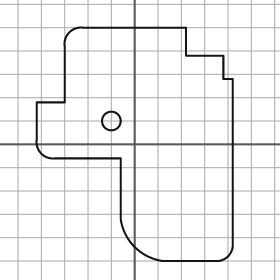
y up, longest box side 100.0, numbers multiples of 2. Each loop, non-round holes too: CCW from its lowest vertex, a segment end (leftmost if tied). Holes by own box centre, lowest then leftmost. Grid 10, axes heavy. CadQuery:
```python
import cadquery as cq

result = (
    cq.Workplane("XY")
    .moveTo(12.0, -50.0)
    .lineTo(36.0, -50.0)
    .threePointArc((40.0, -48.0), (42.0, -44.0))
    .lineTo(42.0, 28.0)
    .lineTo(38.0, 28.0)
    .lineTo(38.0, 38.0)
    .lineTo(22.0, 38.0)
    .lineTo(22.0, 50.0)
    .lineTo(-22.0, 50.0)
    .threePointArc((-28.0, 48.0), (-30.0, 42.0))
    .lineTo(-30.0, 18.0)
    .lineTo(-42.0, 18.0)
    .lineTo(-42.0, 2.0)
    .threePointArc((-40.0, -4.0), (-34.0, -6.0))
    .lineTo(-6.0, -6.0)
    .lineTo(-6.0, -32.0)
    .threePointArc((0.0, -44.0), (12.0, -50.0))
    .close()
    .moveTo(-10.0, 10.0)
    .circle(4.0)
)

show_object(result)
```